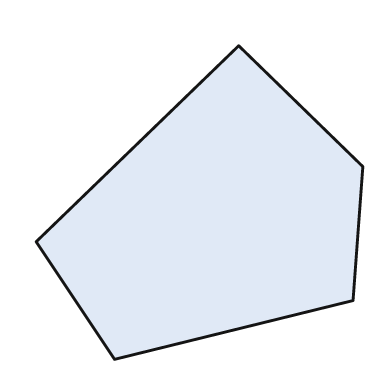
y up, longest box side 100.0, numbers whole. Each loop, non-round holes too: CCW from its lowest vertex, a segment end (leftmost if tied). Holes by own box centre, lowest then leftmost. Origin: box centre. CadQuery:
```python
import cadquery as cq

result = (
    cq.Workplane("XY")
    .moveTo(-26.0, -48.0)
    .lineTo(47.0, -30.0)
    .lineTo(50.0, 11.0)
    .lineTo(12.0, 48.0)
    .lineTo(-50.0, -12.0)
    .close()
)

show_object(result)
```